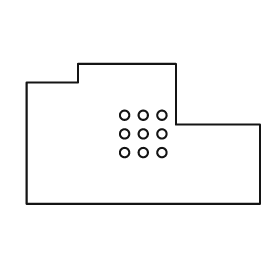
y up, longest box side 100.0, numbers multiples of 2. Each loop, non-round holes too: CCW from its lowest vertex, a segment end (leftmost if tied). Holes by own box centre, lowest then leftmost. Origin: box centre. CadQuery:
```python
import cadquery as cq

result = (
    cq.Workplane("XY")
    .moveTo(-50.0, -30.0)
    .lineTo(50.0, -30.0)
    .lineTo(50.0, 4.0)
    .lineTo(14.0, 4.0)
    .lineTo(14.0, 30.0)
    .lineTo(-28.0, 30.0)
    .lineTo(-28.0, 22.0)
    .lineTo(-50.0, 22.0)
    .close()
    .moveTo(-8.0, -8.0)
    .circle(2.0)
    .moveTo(0.0, -8.0)
    .circle(2.0)
    .moveTo(8.0, -8.0)
    .circle(2.0)
    .moveTo(-8.0, 0.0)
    .circle(2.0)
    .moveTo(0.0, 0.0)
    .circle(2.0)
    .moveTo(8.0, 0.0)
    .circle(2.0)
    .moveTo(-8.0, 8.0)
    .circle(2.0)
    .moveTo(0.0, 8.0)
    .circle(2.0)
    .moveTo(8.0, 8.0)
    .circle(2.0)
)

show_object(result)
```